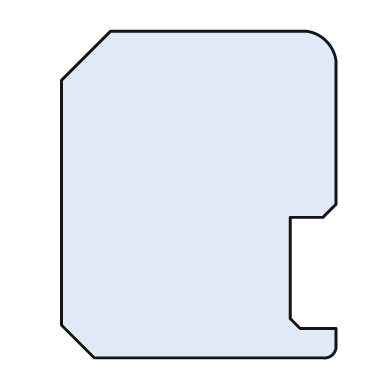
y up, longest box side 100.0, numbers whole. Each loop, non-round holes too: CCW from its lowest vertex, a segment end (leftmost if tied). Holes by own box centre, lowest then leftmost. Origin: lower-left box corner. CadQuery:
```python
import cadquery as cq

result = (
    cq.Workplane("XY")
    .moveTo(10.0, 0.0)
    .lineTo(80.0, 0.0)
    .threePointArc((83.0, 1.0), (84.0, 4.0))
    .lineTo(84.0, 9.0)
    .lineTo(73.0, 9.0)
    .lineTo(70.0, 12.0)
    .lineTo(70.0, 43.0)
    .lineTo(80.0, 43.0)
    .lineTo(84.0, 47.0)
    .lineTo(84.0, 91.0)
    .threePointArc((81.0, 97.0), (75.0, 100.0))
    .lineTo(15.0, 100.0)
    .lineTo(0.0, 85.0)
    .lineTo(0.0, 10.0)
    .close()
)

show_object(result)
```